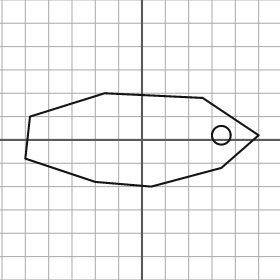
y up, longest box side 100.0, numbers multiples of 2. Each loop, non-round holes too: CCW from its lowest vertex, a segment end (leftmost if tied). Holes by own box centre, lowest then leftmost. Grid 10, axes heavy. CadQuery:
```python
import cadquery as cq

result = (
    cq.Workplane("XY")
    .moveTo(4.0, -20.0)
    .lineTo(34.0, -12.0)
    .lineTo(50.0, 2.0)
    .lineTo(26.0, 18.0)
    .lineTo(-16.0, 20.0)
    .lineTo(-48.0, 10.0)
    .lineTo(-50.0, -8.0)
    .lineTo(-20.0, -18.0)
    .close()
    .moveTo(34.0, 2.0)
    .circle(4.0)
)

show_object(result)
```